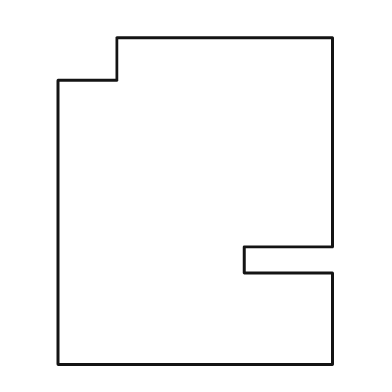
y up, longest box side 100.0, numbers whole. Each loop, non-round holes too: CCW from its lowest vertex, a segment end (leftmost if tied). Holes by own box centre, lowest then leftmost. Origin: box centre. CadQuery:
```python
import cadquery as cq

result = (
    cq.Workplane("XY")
    .moveTo(-42.0, -50.0)
    .lineTo(42.0, -50.0)
    .lineTo(42.0, -22.0)
    .lineTo(15.0, -22.0)
    .lineTo(15.0, -14.0)
    .lineTo(42.0, -14.0)
    .lineTo(42.0, 50.0)
    .lineTo(-24.0, 50.0)
    .lineTo(-24.0, 37.0)
    .lineTo(-42.0, 37.0)
    .close()
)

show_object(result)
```